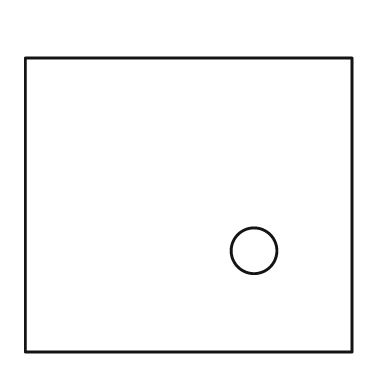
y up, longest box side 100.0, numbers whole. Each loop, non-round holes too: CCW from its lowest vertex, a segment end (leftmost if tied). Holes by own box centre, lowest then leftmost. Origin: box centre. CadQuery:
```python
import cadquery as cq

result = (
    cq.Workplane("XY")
    .moveTo(-50.0, -45.0)
    .lineTo(50.0, -45.0)
    .lineTo(50.0, 45.0)
    .lineTo(-50.0, 45.0)
    .close()
    .moveTo(20.0, -14.0)
    .circle(7.0)
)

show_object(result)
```